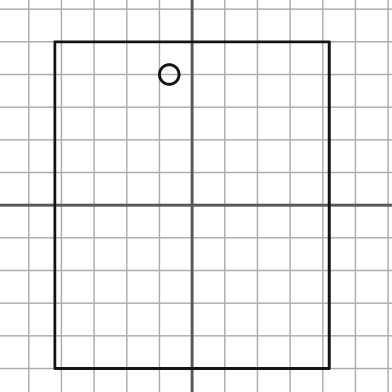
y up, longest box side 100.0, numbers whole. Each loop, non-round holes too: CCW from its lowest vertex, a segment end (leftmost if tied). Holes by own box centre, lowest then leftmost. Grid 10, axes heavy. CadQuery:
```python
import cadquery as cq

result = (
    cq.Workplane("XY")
    .moveTo(-42.0, -50.0)
    .lineTo(42.0, -50.0)
    .lineTo(42.0, 50.0)
    .lineTo(-42.0, 50.0)
    .close()
    .moveTo(-7.0, 40.0)
    .circle(3.0)
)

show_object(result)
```